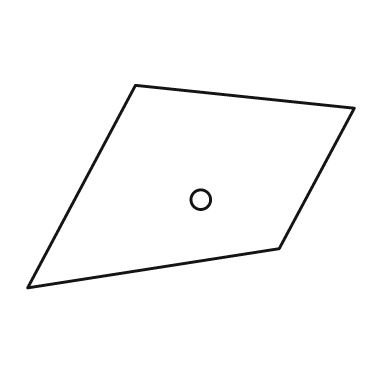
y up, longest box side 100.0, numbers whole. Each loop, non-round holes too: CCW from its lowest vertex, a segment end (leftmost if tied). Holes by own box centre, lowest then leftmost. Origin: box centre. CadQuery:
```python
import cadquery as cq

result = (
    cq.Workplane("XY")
    .moveTo(-50.0, -31.0)
    .lineTo(27.0, -19.0)
    .lineTo(50.0, 24.0)
    .lineTo(-17.0, 31.0)
    .close()
    .moveTo(3.0, -4.0)
    .circle(3.0)
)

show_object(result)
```